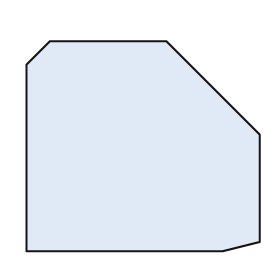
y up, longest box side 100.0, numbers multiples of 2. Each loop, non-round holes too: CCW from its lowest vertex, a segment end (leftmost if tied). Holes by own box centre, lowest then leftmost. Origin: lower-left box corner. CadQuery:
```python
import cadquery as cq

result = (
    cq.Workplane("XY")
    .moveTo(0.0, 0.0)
    .lineTo(84.0, 0.0)
    .lineTo(100.0, 4.0)
    .lineTo(100.0, 50.0)
    .lineTo(60.0, 90.0)
    .lineTo(10.0, 90.0)
    .lineTo(0.0, 80.0)
    .close()
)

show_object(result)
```